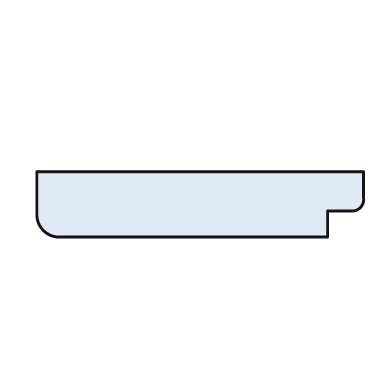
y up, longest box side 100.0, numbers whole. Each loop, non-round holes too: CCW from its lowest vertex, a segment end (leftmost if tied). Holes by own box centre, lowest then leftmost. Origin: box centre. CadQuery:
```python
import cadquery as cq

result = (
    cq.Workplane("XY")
    .moveTo(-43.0, -10.0)
    .lineTo(39.0, -10.0)
    .lineTo(39.0, -2.0)
    .lineTo(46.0, -2.0)
    .threePointArc((49.0, -1.0), (50.0, 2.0))
    .lineTo(50.0, 10.0)
    .lineTo(-50.0, 10.0)
    .lineTo(-50.0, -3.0)
    .threePointArc((-48.0, -8.0), (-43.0, -10.0))
    .close()
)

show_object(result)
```